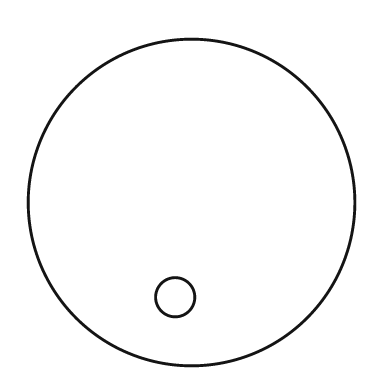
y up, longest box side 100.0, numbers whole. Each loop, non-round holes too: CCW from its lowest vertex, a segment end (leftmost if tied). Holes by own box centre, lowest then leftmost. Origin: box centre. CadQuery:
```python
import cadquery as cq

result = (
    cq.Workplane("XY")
    .moveTo(0.0, 0.0)
    .circle(50.0)
    .moveTo(-5.0, -29.0)
    .circle(6.0)
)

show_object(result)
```